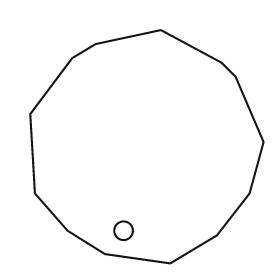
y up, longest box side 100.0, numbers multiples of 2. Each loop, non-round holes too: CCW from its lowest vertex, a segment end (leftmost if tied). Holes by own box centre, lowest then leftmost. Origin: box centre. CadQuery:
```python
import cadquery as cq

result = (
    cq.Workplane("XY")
    .moveTo(10.0, -50.0)
    .lineTo(30.0, -38.0)
    .lineTo(44.0, -20.0)
    .lineTo(50.0, 2.0)
    .lineTo(38.0, 30.0)
    .lineTo(32.0, 36.0)
    .lineTo(6.0, 50.0)
    .lineTo(-22.0, 44.0)
    .lineTo(-32.0, 38.0)
    .lineTo(-50.0, 14.0)
    .lineTo(-48.0, -20.0)
    .lineTo(-34.0, -36.0)
    .lineTo(-18.0, -46.0)
    .close()
    .moveTo(-10.0, -36.0)
    .circle(4.0)
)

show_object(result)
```